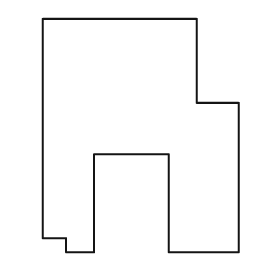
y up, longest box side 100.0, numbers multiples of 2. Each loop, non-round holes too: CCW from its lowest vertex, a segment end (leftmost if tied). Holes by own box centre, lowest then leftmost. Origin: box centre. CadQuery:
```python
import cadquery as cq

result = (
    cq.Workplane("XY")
    .moveTo(-32.0, -50.0)
    .lineTo(-20.0, -50.0)
    .lineTo(-20.0, -8.0)
    .lineTo(12.0, -8.0)
    .lineTo(12.0, -50.0)
    .lineTo(42.0, -50.0)
    .lineTo(42.0, 14.0)
    .lineTo(24.0, 14.0)
    .lineTo(24.0, 50.0)
    .lineTo(-42.0, 50.0)
    .lineTo(-42.0, -44.0)
    .lineTo(-32.0, -44.0)
    .close()
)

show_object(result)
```